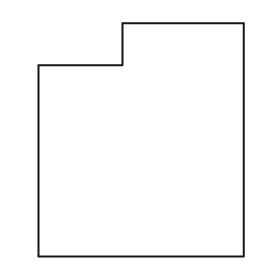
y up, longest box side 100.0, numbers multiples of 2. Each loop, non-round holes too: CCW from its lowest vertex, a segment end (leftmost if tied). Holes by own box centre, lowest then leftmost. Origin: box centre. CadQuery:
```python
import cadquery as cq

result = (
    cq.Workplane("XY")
    .moveTo(-44.0, -50.0)
    .lineTo(44.0, -50.0)
    .lineTo(44.0, 50.0)
    .lineTo(-8.0, 50.0)
    .lineTo(-8.0, 32.0)
    .lineTo(-44.0, 32.0)
    .close()
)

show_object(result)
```